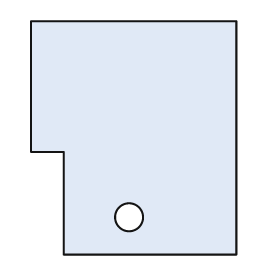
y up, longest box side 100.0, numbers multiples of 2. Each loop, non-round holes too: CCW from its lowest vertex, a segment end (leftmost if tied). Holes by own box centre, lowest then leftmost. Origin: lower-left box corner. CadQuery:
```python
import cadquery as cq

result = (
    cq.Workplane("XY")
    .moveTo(14.0, 0.0)
    .lineTo(88.0, 0.0)
    .lineTo(88.0, 100.0)
    .lineTo(0.0, 100.0)
    .lineTo(0.0, 44.0)
    .lineTo(14.0, 44.0)
    .close()
    .moveTo(42.0, 16.0)
    .circle(6.0)
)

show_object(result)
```